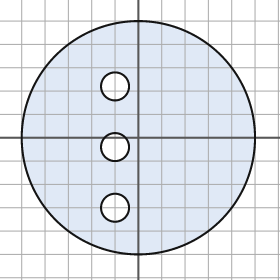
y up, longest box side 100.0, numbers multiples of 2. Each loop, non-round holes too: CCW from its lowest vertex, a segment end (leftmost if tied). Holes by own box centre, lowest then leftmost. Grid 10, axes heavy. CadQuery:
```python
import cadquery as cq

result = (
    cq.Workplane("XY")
    .moveTo(0.0, 0.0)
    .circle(50.0)
    .moveTo(-10.0, -30.0)
    .circle(6.0)
    .moveTo(-10.0, -4.0)
    .circle(6.0)
    .moveTo(-10.0, 22.0)
    .circle(6.0)
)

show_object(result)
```